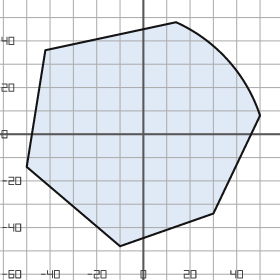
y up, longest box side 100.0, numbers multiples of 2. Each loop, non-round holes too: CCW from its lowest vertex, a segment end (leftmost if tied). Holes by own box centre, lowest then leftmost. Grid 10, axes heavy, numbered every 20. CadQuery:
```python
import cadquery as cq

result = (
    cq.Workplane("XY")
    .moveTo(-10.0, -48.0)
    .lineTo(30.0, -34.0)
    .lineTo(50.0, 8.0)
    .threePointArc((36.0, 32.0), (14.0, 48.0))
    .lineTo(-42.0, 36.0)
    .lineTo(-50.0, -14.0)
    .close()
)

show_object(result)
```